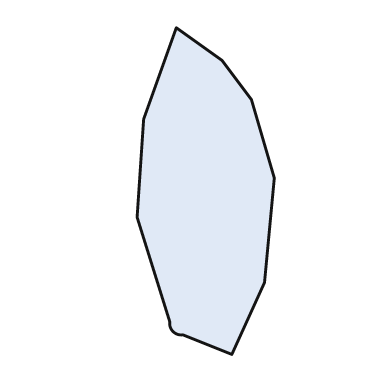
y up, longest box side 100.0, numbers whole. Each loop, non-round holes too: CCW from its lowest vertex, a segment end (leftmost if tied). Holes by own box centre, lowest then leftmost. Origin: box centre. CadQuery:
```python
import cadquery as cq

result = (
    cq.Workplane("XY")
    .moveTo(8.0, -50.0)
    .lineTo(18.0, -28.0)
    .lineTo(21.0, 4.0)
    .lineTo(14.0, 28.0)
    .lineTo(5.0, 40.0)
    .lineTo(-9.0, 50.0)
    .lineTo(-19.0, 22.0)
    .lineTo(-21.0, -8.0)
    .lineTo(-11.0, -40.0)
    .threePointArc((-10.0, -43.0), (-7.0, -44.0))
    .close()
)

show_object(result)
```